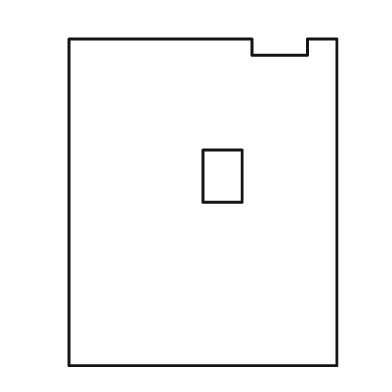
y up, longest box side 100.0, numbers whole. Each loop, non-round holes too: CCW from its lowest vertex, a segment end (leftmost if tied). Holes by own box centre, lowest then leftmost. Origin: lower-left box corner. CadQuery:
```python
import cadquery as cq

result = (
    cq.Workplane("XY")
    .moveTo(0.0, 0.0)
    .lineTo(82.0, 0.0)
    .lineTo(82.0, 100.0)
    .lineTo(73.0, 100.0)
    .lineTo(73.0, 95.0)
    .lineTo(56.0, 95.0)
    .lineTo(56.0, 100.0)
    .lineTo(0.0, 100.0)
    .close()
    .moveTo(41.0, 50.0)
    .lineTo(53.0, 50.0)
    .lineTo(53.0, 66.0)
    .lineTo(41.0, 66.0)
    .close()
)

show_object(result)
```